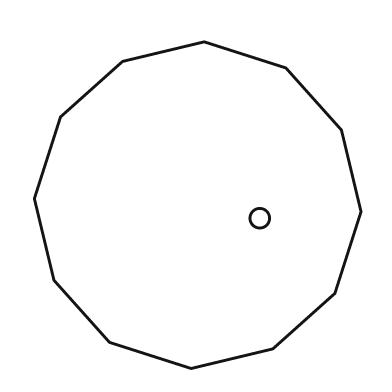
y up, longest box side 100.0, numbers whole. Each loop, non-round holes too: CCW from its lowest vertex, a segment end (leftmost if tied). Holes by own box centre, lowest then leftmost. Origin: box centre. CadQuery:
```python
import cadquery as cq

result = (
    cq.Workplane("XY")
    .moveTo(-2.0, -50.0)
    .lineTo(23.0, -44.0)
    .lineTo(42.0, -27.0)
    .lineTo(50.0, -2.0)
    .lineTo(44.0, 23.0)
    .lineTo(27.0, 42.0)
    .lineTo(2.0, 50.0)
    .lineTo(-23.0, 44.0)
    .lineTo(-42.0, 27.0)
    .lineTo(-50.0, 2.0)
    .lineTo(-44.0, -23.0)
    .lineTo(-27.0, -42.0)
    .close()
    .moveTo(19.0, -4.0)
    .circle(3.0)
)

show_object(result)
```